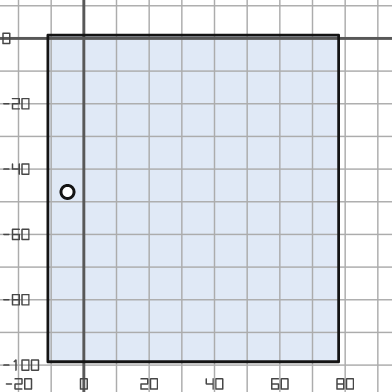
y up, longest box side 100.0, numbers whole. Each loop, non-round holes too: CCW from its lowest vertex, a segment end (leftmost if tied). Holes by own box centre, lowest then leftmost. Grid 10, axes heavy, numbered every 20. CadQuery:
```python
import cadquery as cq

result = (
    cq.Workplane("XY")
    .moveTo(-11.0, -99.0)
    .lineTo(78.0, -99.0)
    .lineTo(78.0, 1.0)
    .lineTo(-11.0, 1.0)
    .close()
    .moveTo(-5.0, -47.0)
    .circle(2.0)
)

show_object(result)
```